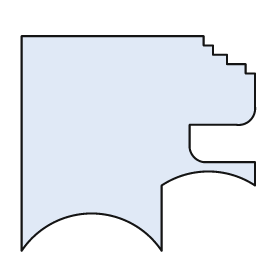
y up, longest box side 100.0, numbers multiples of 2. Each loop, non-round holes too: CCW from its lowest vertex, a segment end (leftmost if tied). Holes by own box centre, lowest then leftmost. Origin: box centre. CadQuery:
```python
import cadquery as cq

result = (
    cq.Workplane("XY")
    .moveTo(-50.0, -46.0)
    .threePointArc((-20.0, -30.0), (10.0, -46.0))
    .lineTo(10.0, -18.0)
    .threePointArc((30.0, -12.0), (50.0, -18.0))
    .lineTo(50.0, -8.0)
    .lineTo(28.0, -8.0)
    .threePointArc((24.0, -6.0), (22.0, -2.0))
    .lineTo(22.0, 8.0)
    .lineTo(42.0, 8.0)
    .threePointArc((48.0, 10.0), (50.0, 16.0))
    .lineTo(50.0, 30.0)
    .lineTo(46.0, 30.0)
    .lineTo(46.0, 34.0)
    .lineTo(38.0, 34.0)
    .lineTo(38.0, 38.0)
    .lineTo(32.0, 38.0)
    .lineTo(32.0, 42.0)
    .lineTo(28.0, 42.0)
    .lineTo(28.0, 46.0)
    .lineTo(-50.0, 46.0)
    .close()
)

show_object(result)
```